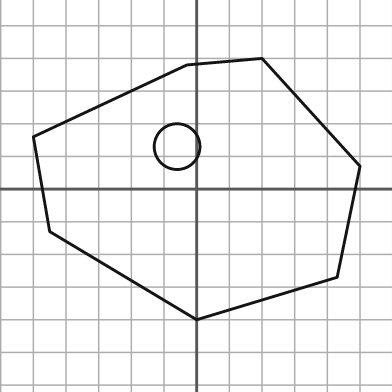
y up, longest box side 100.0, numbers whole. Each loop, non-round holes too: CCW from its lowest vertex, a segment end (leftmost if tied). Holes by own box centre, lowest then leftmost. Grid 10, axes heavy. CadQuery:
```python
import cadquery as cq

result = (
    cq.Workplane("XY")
    .moveTo(0.0, -40.0)
    .lineTo(43.0, -27.0)
    .lineTo(50.0, 7.0)
    .lineTo(20.0, 40.0)
    .lineTo(-3.0, 38.0)
    .lineTo(-50.0, 16.0)
    .lineTo(-45.0, -13.0)
    .close()
    .moveTo(-6.0, 13.0)
    .circle(7.0)
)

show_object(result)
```